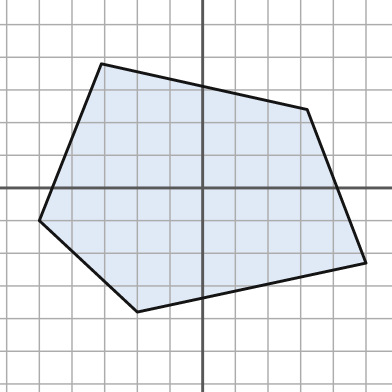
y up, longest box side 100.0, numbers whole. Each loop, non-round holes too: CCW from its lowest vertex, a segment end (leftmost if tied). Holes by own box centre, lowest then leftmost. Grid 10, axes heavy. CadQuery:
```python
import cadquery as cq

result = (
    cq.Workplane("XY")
    .moveTo(-20.0, -38.0)
    .lineTo(50.0, -23.0)
    .lineTo(32.0, 24.0)
    .lineTo(-31.0, 38.0)
    .lineTo(-50.0, -10.0)
    .close()
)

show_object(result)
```